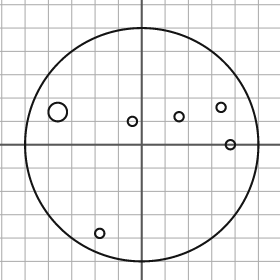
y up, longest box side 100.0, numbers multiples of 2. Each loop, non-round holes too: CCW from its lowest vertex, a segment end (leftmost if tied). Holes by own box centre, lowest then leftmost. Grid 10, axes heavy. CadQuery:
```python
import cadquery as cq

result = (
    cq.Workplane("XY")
    .moveTo(0.0, 0.0)
    .circle(50.0)
    .moveTo(-18.0, -38.0)
    .circle(2.0)
    .moveTo(38.0, 0.0)
    .circle(2.0)
    .moveTo(-4.0, 10.0)
    .circle(2.0)
    .moveTo(16.0, 12.0)
    .circle(2.0)
    .moveTo(-36.0, 14.0)
    .circle(4.0)
    .moveTo(34.0, 16.0)
    .circle(2.0)
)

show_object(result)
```